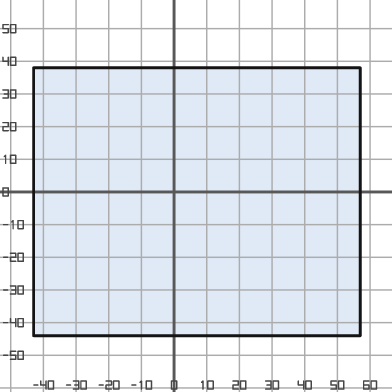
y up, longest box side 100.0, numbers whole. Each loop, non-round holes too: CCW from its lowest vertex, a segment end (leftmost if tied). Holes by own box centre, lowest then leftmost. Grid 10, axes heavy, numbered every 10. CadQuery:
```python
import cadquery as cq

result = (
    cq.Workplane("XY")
    .moveTo(-43.0, -44.0)
    .lineTo(57.0, -44.0)
    .lineTo(57.0, 38.0)
    .lineTo(-43.0, 38.0)
    .close()
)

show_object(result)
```